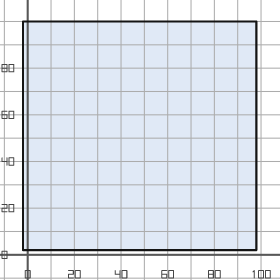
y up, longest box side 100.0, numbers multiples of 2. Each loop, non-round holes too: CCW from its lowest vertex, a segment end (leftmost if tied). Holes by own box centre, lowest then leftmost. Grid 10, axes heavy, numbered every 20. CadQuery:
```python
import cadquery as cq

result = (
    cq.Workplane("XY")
    .moveTo(-2.0, 2.0)
    .lineTo(98.0, 2.0)
    .lineTo(98.0, 100.0)
    .lineTo(-2.0, 100.0)
    .close()
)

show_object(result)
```